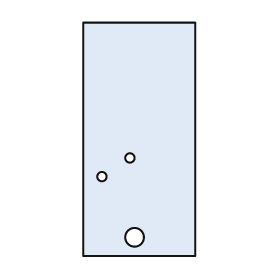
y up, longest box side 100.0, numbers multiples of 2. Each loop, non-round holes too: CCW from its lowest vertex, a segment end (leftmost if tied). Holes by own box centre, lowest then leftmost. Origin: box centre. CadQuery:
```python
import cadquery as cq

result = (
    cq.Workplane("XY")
    .moveTo(-24.0, -50.0)
    .lineTo(24.0, -50.0)
    .lineTo(24.0, 50.0)
    .lineTo(-24.0, 50.0)
    .close()
    .moveTo(-2.0, -42.0)
    .circle(4.0)
    .moveTo(-16.0, -16.0)
    .circle(2.0)
    .moveTo(-4.0, -8.0)
    .circle(2.0)
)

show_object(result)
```